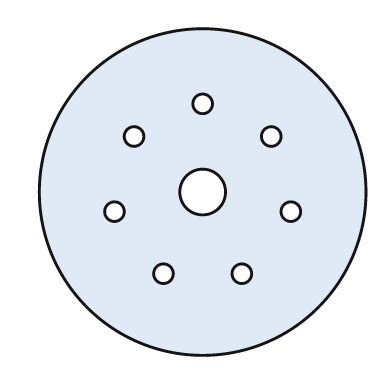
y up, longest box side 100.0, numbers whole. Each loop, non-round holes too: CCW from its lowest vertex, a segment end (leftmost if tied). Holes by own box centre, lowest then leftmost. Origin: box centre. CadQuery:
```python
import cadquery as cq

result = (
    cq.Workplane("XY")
    .moveTo(0.0, 0.0)
    .circle(50.0)
    .moveTo(-12.0, -25.0)
    .circle(3.0)
    .moveTo(12.0, -25.0)
    .circle(3.0)
    .moveTo(-27.0, -6.0)
    .circle(3.0)
    .moveTo(27.0, -6.0)
    .circle(3.0)
    .moveTo(0.0, 0.0)
    .circle(7.0)
    .moveTo(-21.0, 17.0)
    .circle(3.0)
    .moveTo(21.0, 17.0)
    .circle(3.0)
    .moveTo(0.0, 27.0)
    .circle(3.0)
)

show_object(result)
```